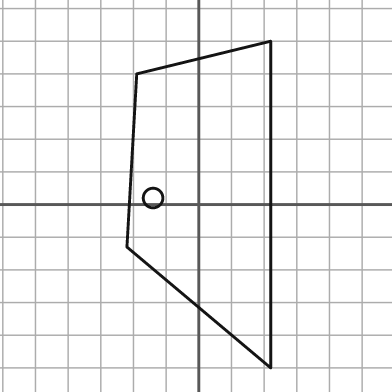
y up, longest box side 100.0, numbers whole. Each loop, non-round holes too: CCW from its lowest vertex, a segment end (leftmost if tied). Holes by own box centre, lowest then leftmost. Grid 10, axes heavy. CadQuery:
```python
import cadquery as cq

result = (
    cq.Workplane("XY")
    .moveTo(22.0, -50.0)
    .lineTo(22.0, 50.0)
    .lineTo(-19.0, 40.0)
    .lineTo(-22.0, -13.0)
    .close()
    .moveTo(-14.0, 2.0)
    .circle(3.0)
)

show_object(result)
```